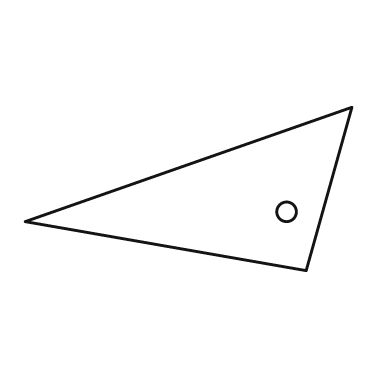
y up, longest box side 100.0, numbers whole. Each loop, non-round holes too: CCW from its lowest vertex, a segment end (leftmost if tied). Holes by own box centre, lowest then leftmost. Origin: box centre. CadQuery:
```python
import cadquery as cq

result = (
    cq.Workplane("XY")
    .moveTo(36.0, -25.0)
    .lineTo(50.0, 25.0)
    .lineTo(-50.0, -10.0)
    .close()
    .moveTo(30.0, -7.0)
    .circle(3.0)
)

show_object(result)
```